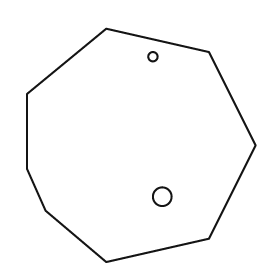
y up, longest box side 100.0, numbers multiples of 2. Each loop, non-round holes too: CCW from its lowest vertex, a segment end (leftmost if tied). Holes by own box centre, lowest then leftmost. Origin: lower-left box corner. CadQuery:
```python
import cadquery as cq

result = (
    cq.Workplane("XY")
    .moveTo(34.0, 0.0)
    .lineTo(78.0, 10.0)
    .lineTo(98.0, 50.0)
    .lineTo(78.0, 90.0)
    .lineTo(34.0, 100.0)
    .lineTo(0.0, 72.0)
    .lineTo(0.0, 40.0)
    .lineTo(8.0, 22.0)
    .close()
    .moveTo(58.0, 28.0)
    .circle(4.0)
    .moveTo(54.0, 88.0)
    .circle(2.0)
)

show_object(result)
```